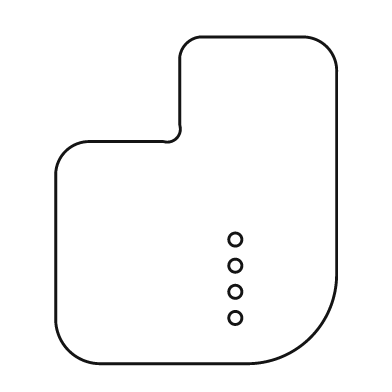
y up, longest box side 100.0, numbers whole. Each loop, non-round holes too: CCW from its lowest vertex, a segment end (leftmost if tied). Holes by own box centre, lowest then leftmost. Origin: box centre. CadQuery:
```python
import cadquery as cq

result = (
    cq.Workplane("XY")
    .moveTo(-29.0, -50.0)
    .lineTo(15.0, -50.0)
    .threePointArc((35.0, -42.0), (43.0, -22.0))
    .lineTo(43.0, 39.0)
    .threePointArc((40.0, 47.0), (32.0, 50.0))
    .lineTo(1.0, 50.0)
    .threePointArc((-3.0, 48.0), (-5.0, 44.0))
    .lineTo(-5.0, 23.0)
    .threePointArc((-6.0, 19.0), (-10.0, 18.0))
    .lineTo(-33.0, 18.0)
    .threePointArc((-40.0, 15.0), (-43.0, 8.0))
    .lineTo(-43.0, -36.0)
    .threePointArc((-39.0, -46.0), (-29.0, -50.0))
    .close()
    .moveTo(12.0, -36.0)
    .circle(2.0)
    .moveTo(12.0, -28.0)
    .circle(2.0)
    .moveTo(12.0, -20.0)
    .circle(2.0)
    .moveTo(12.0, -12.0)
    .circle(2.0)
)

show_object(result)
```